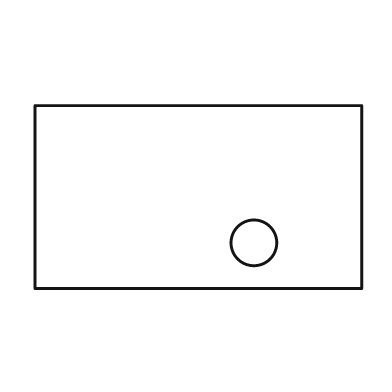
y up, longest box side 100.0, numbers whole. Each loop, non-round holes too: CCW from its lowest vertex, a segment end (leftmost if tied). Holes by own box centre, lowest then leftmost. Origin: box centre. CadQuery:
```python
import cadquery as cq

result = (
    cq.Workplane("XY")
    .moveTo(-50.0, -28.0)
    .lineTo(50.0, -28.0)
    .lineTo(50.0, 28.0)
    .lineTo(-50.0, 28.0)
    .close()
    .moveTo(17.0, -14.0)
    .circle(7.0)
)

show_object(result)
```